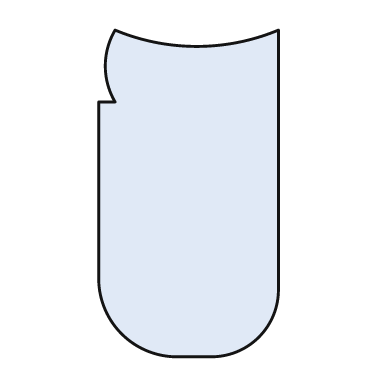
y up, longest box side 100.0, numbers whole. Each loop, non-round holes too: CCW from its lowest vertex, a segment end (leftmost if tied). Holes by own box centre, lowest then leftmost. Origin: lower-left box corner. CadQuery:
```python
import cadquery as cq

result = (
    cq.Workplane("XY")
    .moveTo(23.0, 0.0)
    .lineTo(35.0, 0.0)
    .threePointArc((49.0, 6.0), (55.0, 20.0))
    .lineTo(55.0, 100.0)
    .threePointArc((30.0, 95.0), (5.0, 100.0))
    .threePointArc((2.0, 89.0), (5.0, 78.0))
    .lineTo(0.0, 78.0)
    .lineTo(0.0, 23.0)
    .threePointArc((7.0, 7.0), (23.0, 0.0))
    .close()
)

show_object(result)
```